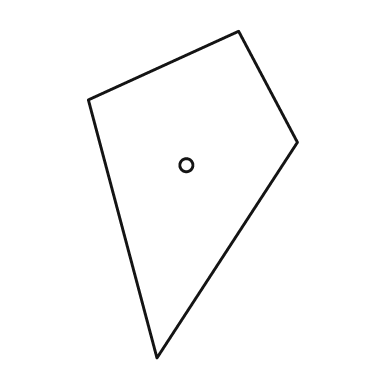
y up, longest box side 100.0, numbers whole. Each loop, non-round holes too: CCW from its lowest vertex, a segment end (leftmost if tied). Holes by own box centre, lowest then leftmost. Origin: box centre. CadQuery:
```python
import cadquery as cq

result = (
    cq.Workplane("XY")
    .moveTo(-11.0, -50.0)
    .lineTo(32.0, 16.0)
    .lineTo(14.0, 50.0)
    .lineTo(-32.0, 29.0)
    .close()
    .moveTo(-2.0, 9.0)
    .circle(2.0)
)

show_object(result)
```